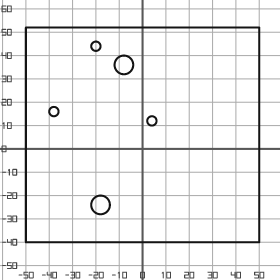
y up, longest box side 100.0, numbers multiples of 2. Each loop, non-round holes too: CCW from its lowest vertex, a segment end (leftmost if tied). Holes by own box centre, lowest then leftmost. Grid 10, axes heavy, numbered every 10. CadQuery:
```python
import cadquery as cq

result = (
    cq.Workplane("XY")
    .moveTo(-50.0, -40.0)
    .lineTo(50.0, -40.0)
    .lineTo(50.0, 52.0)
    .lineTo(-50.0, 52.0)
    .close()
    .moveTo(-18.0, -24.0)
    .circle(4.0)
    .moveTo(4.0, 12.0)
    .circle(2.0)
    .moveTo(-38.0, 16.0)
    .circle(2.0)
    .moveTo(-8.0, 36.0)
    .circle(4.0)
    .moveTo(-20.0, 44.0)
    .circle(2.0)
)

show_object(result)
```